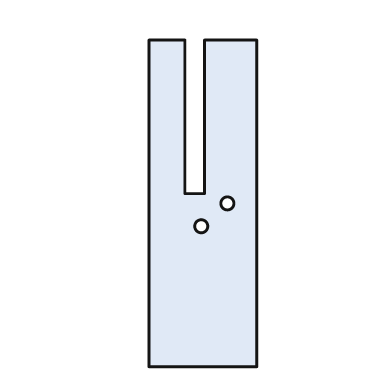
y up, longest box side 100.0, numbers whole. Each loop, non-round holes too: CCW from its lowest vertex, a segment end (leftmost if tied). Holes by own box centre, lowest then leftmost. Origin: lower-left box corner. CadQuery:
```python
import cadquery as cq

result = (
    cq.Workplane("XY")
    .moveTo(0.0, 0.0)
    .lineTo(33.0, 0.0)
    .lineTo(33.0, 100.0)
    .lineTo(17.0, 100.0)
    .lineTo(17.0, 53.0)
    .lineTo(11.0, 53.0)
    .lineTo(11.0, 100.0)
    .lineTo(0.0, 100.0)
    .close()
    .moveTo(16.0, 43.0)
    .circle(2.0)
    .moveTo(24.0, 50.0)
    .circle(2.0)
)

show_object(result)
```